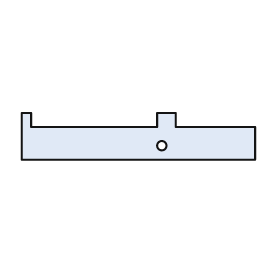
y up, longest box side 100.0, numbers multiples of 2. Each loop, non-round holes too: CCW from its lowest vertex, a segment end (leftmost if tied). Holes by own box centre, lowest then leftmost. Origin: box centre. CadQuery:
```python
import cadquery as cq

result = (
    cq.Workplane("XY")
    .moveTo(-50.0, -10.0)
    .lineTo(50.0, -10.0)
    .lineTo(50.0, 4.0)
    .lineTo(16.0, 4.0)
    .lineTo(16.0, 10.0)
    .lineTo(8.0, 10.0)
    .lineTo(8.0, 4.0)
    .lineTo(-46.0, 4.0)
    .lineTo(-46.0, 10.0)
    .lineTo(-50.0, 10.0)
    .close()
    .moveTo(10.0, -4.0)
    .circle(2.0)
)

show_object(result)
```